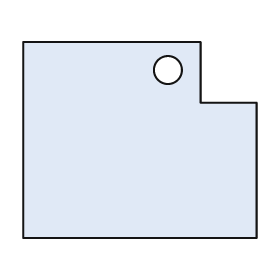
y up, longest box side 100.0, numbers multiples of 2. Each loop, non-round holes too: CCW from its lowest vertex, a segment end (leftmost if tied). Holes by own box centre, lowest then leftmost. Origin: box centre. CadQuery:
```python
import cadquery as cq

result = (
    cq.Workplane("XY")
    .moveTo(-50.0, -42.0)
    .lineTo(50.0, -42.0)
    .lineTo(50.0, 16.0)
    .lineTo(26.0, 16.0)
    .lineTo(26.0, 42.0)
    .lineTo(-50.0, 42.0)
    .close()
    .moveTo(12.0, 30.0)
    .circle(6.0)
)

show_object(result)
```